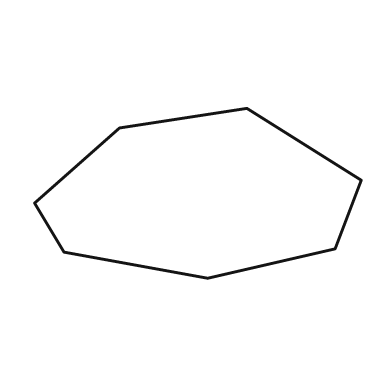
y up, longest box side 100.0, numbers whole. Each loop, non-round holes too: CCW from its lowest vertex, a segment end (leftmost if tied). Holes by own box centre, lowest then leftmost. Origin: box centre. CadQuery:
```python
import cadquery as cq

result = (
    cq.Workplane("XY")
    .moveTo(3.0, -26.0)
    .lineTo(42.0, -17.0)
    .lineTo(50.0, 4.0)
    .lineTo(15.0, 26.0)
    .lineTo(-24.0, 20.0)
    .lineTo(-50.0, -3.0)
    .lineTo(-41.0, -18.0)
    .close()
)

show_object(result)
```